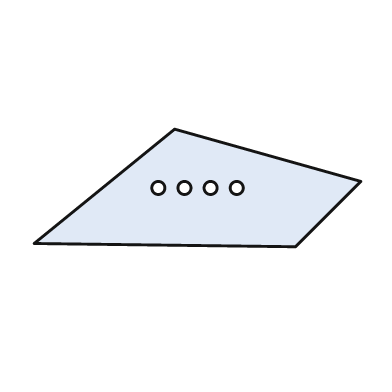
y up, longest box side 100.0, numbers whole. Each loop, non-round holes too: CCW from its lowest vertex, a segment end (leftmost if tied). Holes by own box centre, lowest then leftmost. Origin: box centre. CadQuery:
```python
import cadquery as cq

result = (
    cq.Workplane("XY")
    .moveTo(30.0, -18.0)
    .lineTo(50.0, 2.0)
    .lineTo(-7.0, 18.0)
    .lineTo(-50.0, -17.0)
    .close()
    .moveTo(-12.0, 0.0)
    .circle(2.0)
    .moveTo(-4.0, 0.0)
    .circle(2.0)
    .moveTo(4.0, 0.0)
    .circle(2.0)
    .moveTo(12.0, 0.0)
    .circle(2.0)
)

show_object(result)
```